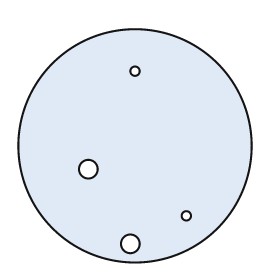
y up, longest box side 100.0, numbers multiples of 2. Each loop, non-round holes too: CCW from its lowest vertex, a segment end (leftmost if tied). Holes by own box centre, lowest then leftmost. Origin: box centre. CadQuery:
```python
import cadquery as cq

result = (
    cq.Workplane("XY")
    .moveTo(0.0, 0.0)
    .circle(50.0)
    .moveTo(-2.0, -42.0)
    .circle(4.0)
    .moveTo(22.0, -30.0)
    .circle(2.0)
    .moveTo(-20.0, -10.0)
    .circle(4.0)
    .moveTo(0.0, 32.0)
    .circle(2.0)
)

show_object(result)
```